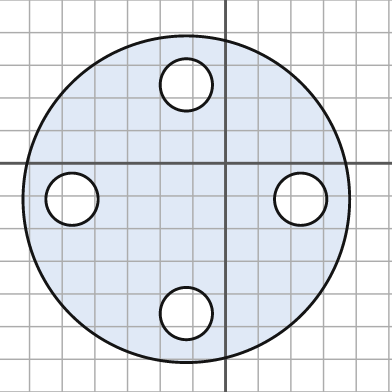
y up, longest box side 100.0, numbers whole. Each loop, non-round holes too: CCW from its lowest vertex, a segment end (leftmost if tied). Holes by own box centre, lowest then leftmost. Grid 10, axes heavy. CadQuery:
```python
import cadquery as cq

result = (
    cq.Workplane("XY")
    .moveTo(-12.0, -11.0)
    .circle(50.0)
    .moveTo(-12.0, -46.0)
    .circle(8.0)
    .moveTo(-47.0, -11.0)
    .circle(8.0)
    .moveTo(23.0, -11.0)
    .circle(8.0)
    .moveTo(-12.0, 24.0)
    .circle(8.0)
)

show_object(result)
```